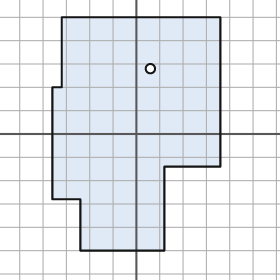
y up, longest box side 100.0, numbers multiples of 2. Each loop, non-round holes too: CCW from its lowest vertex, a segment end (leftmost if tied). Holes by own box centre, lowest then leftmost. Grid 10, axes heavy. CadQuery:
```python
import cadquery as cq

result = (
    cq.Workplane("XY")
    .moveTo(-24.0, -50.0)
    .lineTo(12.0, -50.0)
    .lineTo(12.0, -14.0)
    .lineTo(36.0, -14.0)
    .lineTo(36.0, 50.0)
    .lineTo(-32.0, 50.0)
    .lineTo(-32.0, 20.0)
    .lineTo(-36.0, 20.0)
    .lineTo(-36.0, -28.0)
    .lineTo(-24.0, -28.0)
    .close()
    .moveTo(6.0, 28.0)
    .circle(2.0)
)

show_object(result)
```